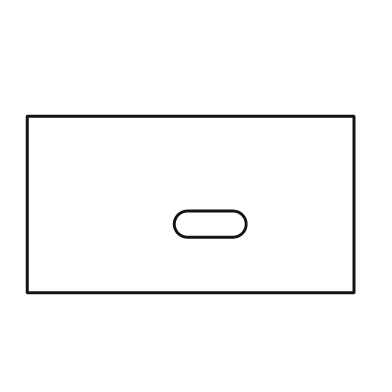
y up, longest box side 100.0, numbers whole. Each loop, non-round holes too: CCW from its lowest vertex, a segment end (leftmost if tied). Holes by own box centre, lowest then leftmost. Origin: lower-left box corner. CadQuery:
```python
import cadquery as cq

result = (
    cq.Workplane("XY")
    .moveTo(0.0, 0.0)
    .lineTo(100.0, 0.0)
    .lineTo(100.0, 54.0)
    .lineTo(0.0, 54.0)
    .close()
    .moveTo(49.0, 17.0)
    .lineTo(63.0, 17.0)
    .threePointArc((67.0, 21.0), (63.0, 25.0))
    .lineTo(49.0, 25.0)
    .threePointArc((45.0, 21.0), (49.0, 17.0))
    .close()
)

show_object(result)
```